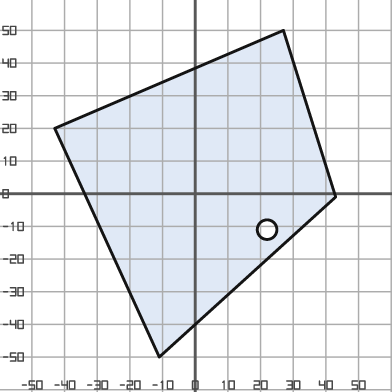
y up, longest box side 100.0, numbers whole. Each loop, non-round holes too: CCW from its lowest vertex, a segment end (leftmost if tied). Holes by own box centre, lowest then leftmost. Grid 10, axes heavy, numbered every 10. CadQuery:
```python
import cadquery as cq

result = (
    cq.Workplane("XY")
    .moveTo(-11.0, -50.0)
    .lineTo(43.0, -1.0)
    .lineTo(27.0, 50.0)
    .lineTo(-43.0, 20.0)
    .close()
    .moveTo(22.0, -11.0)
    .circle(3.0)
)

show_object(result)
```